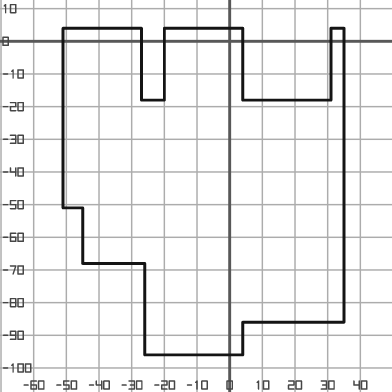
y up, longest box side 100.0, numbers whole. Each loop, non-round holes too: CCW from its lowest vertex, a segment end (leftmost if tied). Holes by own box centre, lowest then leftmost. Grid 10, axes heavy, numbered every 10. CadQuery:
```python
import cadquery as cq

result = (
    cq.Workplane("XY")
    .moveTo(-26.0, -96.0)
    .lineTo(4.0, -96.0)
    .lineTo(4.0, -86.0)
    .lineTo(35.0, -86.0)
    .lineTo(35.0, 4.0)
    .lineTo(31.0, 4.0)
    .lineTo(31.0, -18.0)
    .lineTo(4.0, -18.0)
    .lineTo(4.0, 4.0)
    .lineTo(-20.0, 4.0)
    .lineTo(-20.0, -18.0)
    .lineTo(-27.0, -18.0)
    .lineTo(-27.0, 4.0)
    .lineTo(-51.0, 4.0)
    .lineTo(-51.0, -51.0)
    .lineTo(-45.0, -51.0)
    .lineTo(-45.0, -68.0)
    .lineTo(-26.0, -68.0)
    .close()
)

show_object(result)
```